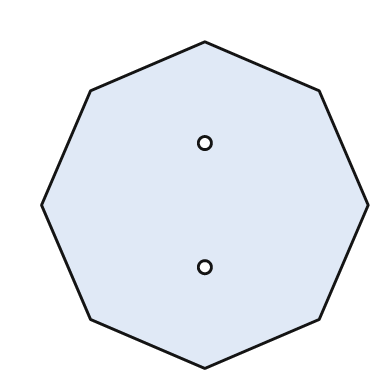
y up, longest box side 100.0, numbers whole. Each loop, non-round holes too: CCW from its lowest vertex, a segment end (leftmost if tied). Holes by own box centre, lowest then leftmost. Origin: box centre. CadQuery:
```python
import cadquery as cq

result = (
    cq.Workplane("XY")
    .moveTo(0.0, -50.0)
    .lineTo(35.0, -35.0)
    .lineTo(50.0, 0.0)
    .lineTo(35.0, 35.0)
    .lineTo(0.0, 50.0)
    .lineTo(-35.0, 35.0)
    .lineTo(-50.0, 0.0)
    .lineTo(-35.0, -35.0)
    .close()
    .moveTo(0.0, -19.0)
    .circle(2.0)
    .moveTo(0.0, 19.0)
    .circle(2.0)
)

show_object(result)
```